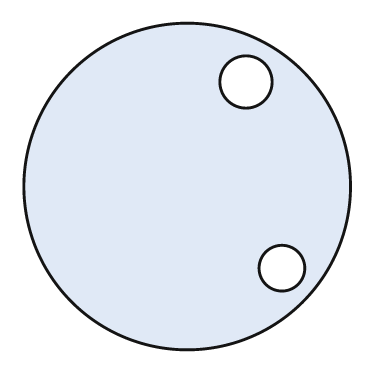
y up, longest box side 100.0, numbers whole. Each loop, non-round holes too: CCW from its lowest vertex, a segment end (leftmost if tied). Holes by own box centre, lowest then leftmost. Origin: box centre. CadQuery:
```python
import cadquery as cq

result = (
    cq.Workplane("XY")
    .moveTo(0.0, 0.0)
    .circle(50.0)
    .moveTo(29.0, -25.0)
    .circle(7.0)
    .moveTo(18.0, 32.0)
    .circle(8.0)
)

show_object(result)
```